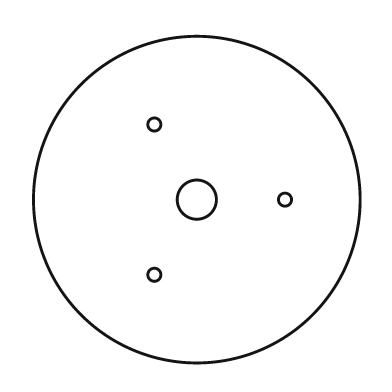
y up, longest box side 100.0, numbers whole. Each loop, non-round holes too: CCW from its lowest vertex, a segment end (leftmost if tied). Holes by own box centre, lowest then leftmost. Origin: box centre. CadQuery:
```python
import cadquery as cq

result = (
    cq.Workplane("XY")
    .moveTo(0.0, 0.0)
    .circle(50.0)
    .moveTo(-13.0, -23.0)
    .circle(2.0)
    .moveTo(0.0, 0.0)
    .circle(6.0)
    .moveTo(27.0, 0.0)
    .circle(2.0)
    .moveTo(-13.0, 23.0)
    .circle(2.0)
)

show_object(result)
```